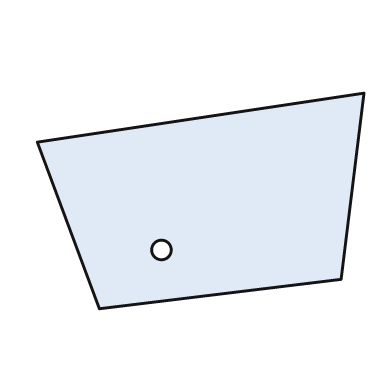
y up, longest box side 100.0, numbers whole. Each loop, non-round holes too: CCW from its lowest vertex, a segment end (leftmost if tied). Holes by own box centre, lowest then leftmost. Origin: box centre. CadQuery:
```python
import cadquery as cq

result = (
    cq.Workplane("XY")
    .moveTo(-31.0, -33.0)
    .lineTo(43.0, -24.0)
    .lineTo(50.0, 33.0)
    .lineTo(-50.0, 18.0)
    .close()
    .moveTo(-12.0, -15.0)
    .circle(3.0)
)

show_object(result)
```